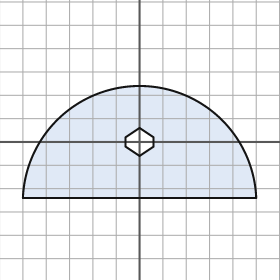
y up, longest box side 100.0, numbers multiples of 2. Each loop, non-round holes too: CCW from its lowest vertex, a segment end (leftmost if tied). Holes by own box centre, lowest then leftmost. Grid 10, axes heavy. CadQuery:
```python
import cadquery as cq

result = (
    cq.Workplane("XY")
    .moveTo(-50.0, -24.0)
    .lineTo(50.0, -24.0)
    .threePointArc((0.0, 24.0), (-50.0, -24.0))
    .close()
    .moveTo(0.0, -6.0)
    .lineTo(6.0, -2.0)
    .lineTo(6.0, 2.0)
    .lineTo(0.0, 6.0)
    .lineTo(-6.0, 2.0)
    .lineTo(-6.0, -2.0)
    .close()
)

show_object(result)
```